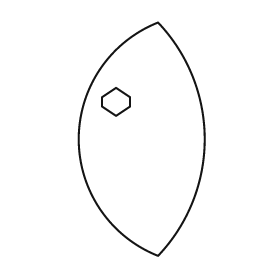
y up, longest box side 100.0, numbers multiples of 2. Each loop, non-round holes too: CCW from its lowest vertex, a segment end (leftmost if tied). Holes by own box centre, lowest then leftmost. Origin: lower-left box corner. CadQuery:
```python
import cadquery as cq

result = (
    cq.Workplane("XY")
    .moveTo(34.0, 0.0)
    .threePointArc((54.0, 50.0), (34.0, 100.0))
    .threePointArc((0.0, 50.0), (34.0, 0.0))
    .close()
    .moveTo(16.0, 60.0)
    .lineTo(22.0, 64.0)
    .lineTo(22.0, 68.0)
    .lineTo(16.0, 72.0)
    .lineTo(10.0, 68.0)
    .lineTo(10.0, 64.0)
    .close()
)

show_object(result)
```